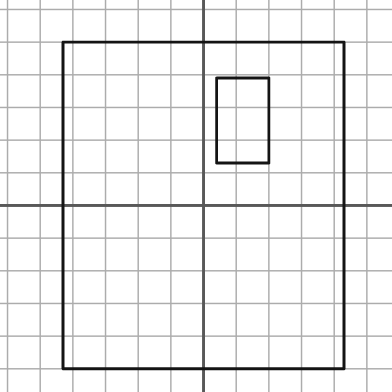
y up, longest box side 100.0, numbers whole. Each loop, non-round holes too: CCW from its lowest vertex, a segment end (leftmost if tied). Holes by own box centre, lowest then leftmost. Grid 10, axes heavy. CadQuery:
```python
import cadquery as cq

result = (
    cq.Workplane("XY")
    .moveTo(-43.0, -50.0)
    .lineTo(43.0, -50.0)
    .lineTo(43.0, 50.0)
    .lineTo(-43.0, 50.0)
    .close()
    .moveTo(4.0, 13.0)
    .lineTo(20.0, 13.0)
    .lineTo(20.0, 39.0)
    .lineTo(4.0, 39.0)
    .close()
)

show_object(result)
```